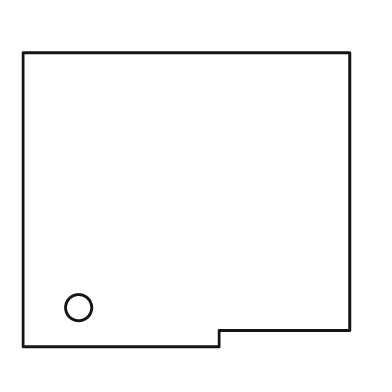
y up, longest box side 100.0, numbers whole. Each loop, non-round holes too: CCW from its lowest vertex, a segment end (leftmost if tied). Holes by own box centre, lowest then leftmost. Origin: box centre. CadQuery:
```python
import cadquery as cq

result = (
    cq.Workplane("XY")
    .moveTo(-50.0, -45.0)
    .lineTo(10.0, -45.0)
    .lineTo(10.0, -40.0)
    .lineTo(50.0, -40.0)
    .lineTo(50.0, 45.0)
    .lineTo(-50.0, 45.0)
    .close()
    .moveTo(-33.0, -33.0)
    .circle(4.0)
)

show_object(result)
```